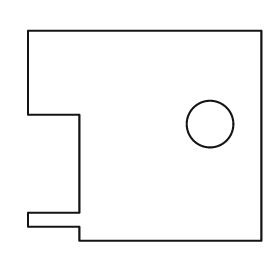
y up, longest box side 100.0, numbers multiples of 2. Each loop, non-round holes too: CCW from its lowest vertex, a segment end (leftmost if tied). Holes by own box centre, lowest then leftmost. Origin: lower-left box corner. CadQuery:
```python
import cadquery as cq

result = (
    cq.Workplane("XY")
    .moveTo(22.0, 0.0)
    .lineTo(100.0, 0.0)
    .lineTo(100.0, 90.0)
    .lineTo(0.0, 90.0)
    .lineTo(0.0, 54.0)
    .lineTo(22.0, 54.0)
    .lineTo(22.0, 12.0)
    .lineTo(0.0, 12.0)
    .lineTo(0.0, 6.0)
    .lineTo(22.0, 6.0)
    .close()
    .moveTo(78.0, 50.0)
    .circle(10.0)
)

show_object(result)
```